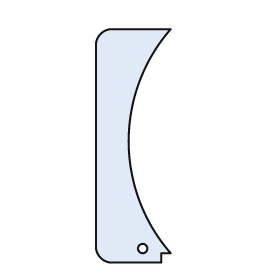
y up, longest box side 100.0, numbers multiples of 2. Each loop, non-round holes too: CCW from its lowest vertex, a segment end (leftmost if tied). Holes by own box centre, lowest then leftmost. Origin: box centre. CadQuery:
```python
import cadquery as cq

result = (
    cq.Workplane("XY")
    .moveTo(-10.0, -50.0)
    .lineTo(12.0, -50.0)
    .lineTo(12.0, -46.0)
    .lineTo(16.0, -46.0)
    .threePointArc((-2.0, 2.0), (16.0, 50.0))
    .lineTo(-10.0, 50.0)
    .threePointArc((-14.0, 48.0), (-16.0, 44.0))
    .lineTo(-16.0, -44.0)
    .threePointArc((-14.0, -48.0), (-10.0, -50.0))
    .close()
    .moveTo(4.0, -44.0)
    .circle(2.0)
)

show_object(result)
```